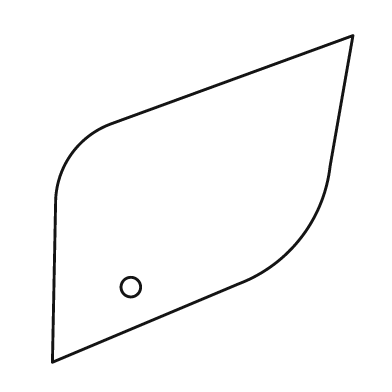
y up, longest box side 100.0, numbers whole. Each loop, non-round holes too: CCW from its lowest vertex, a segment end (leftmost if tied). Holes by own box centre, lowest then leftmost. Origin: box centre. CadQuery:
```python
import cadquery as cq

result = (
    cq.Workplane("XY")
    .moveTo(-46.0, -50.0)
    .lineTo(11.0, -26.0)
    .threePointArc((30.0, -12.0), (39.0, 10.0))
    .lineTo(46.0, 50.0)
    .lineTo(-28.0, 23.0)
    .threePointArc((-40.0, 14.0), (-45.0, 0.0))
    .close()
    .moveTo(-22.0, -27.0)
    .circle(3.0)
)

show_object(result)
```